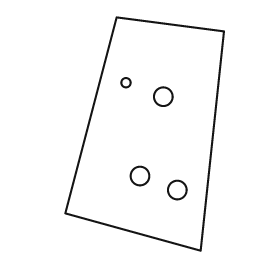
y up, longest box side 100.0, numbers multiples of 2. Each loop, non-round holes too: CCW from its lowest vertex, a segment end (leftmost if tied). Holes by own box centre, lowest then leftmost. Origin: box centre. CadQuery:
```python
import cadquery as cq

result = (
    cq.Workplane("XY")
    .moveTo(24.0, -50.0)
    .lineTo(34.0, 44.0)
    .lineTo(-12.0, 50.0)
    .lineTo(-34.0, -34.0)
    .close()
    .moveTo(14.0, -24.0)
    .circle(4.0)
    .moveTo(-2.0, -18.0)
    .circle(4.0)
    .moveTo(8.0, 16.0)
    .circle(4.0)
    .moveTo(-8.0, 22.0)
    .circle(2.0)
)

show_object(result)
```